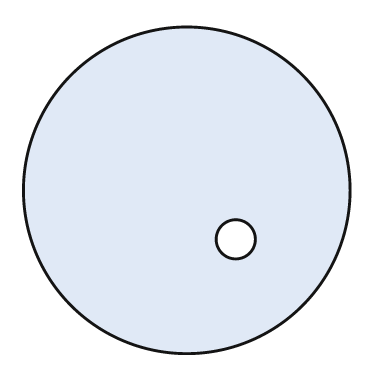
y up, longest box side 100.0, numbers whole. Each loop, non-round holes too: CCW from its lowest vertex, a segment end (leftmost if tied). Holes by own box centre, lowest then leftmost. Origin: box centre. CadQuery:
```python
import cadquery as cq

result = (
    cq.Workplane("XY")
    .moveTo(0.0, 0.0)
    .circle(50.0)
    .moveTo(15.0, -15.0)
    .circle(6.0)
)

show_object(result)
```